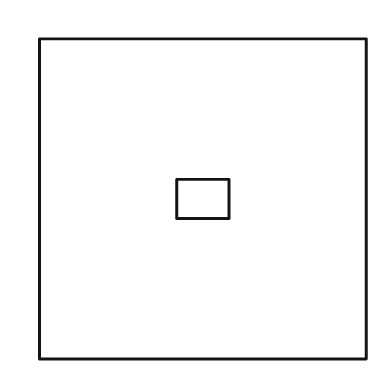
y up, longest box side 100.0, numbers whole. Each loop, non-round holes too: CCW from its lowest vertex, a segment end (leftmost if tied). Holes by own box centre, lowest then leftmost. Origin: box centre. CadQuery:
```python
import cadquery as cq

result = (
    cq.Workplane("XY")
    .moveTo(-50.0, -49.0)
    .lineTo(50.0, -49.0)
    .lineTo(50.0, 49.0)
    .lineTo(-50.0, 49.0)
    .close()
    .moveTo(-8.0, -6.0)
    .lineTo(8.0, -6.0)
    .lineTo(8.0, 6.0)
    .lineTo(-8.0, 6.0)
    .close()
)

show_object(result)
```